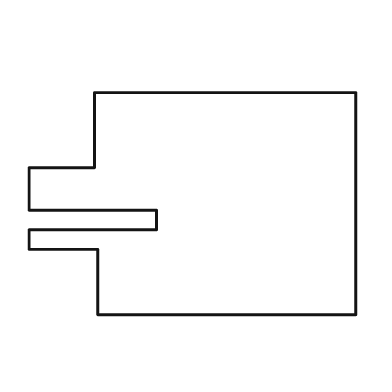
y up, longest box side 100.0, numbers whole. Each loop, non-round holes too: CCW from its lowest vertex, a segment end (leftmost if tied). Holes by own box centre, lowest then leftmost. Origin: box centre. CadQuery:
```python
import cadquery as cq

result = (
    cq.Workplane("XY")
    .moveTo(-29.0, -34.0)
    .lineTo(50.0, -34.0)
    .lineTo(50.0, 34.0)
    .lineTo(-30.0, 34.0)
    .lineTo(-30.0, 11.0)
    .lineTo(-50.0, 11.0)
    .lineTo(-50.0, -2.0)
    .lineTo(-11.0, -2.0)
    .lineTo(-11.0, -8.0)
    .lineTo(-50.0, -8.0)
    .lineTo(-50.0, -14.0)
    .lineTo(-29.0, -14.0)
    .close()
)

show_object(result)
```